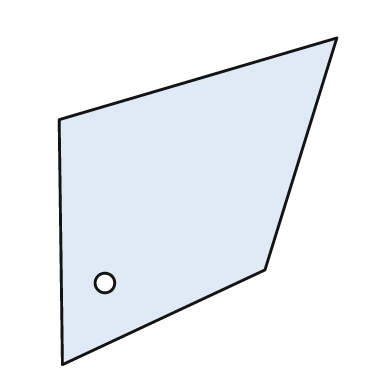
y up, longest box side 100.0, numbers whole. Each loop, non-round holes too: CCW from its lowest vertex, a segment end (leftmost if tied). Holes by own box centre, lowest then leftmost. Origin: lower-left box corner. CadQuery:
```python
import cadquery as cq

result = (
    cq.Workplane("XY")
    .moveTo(1.0, 0.0)
    .lineTo(63.0, 29.0)
    .lineTo(85.0, 100.0)
    .lineTo(0.0, 75.0)
    .close()
    .moveTo(14.0, 25.0)
    .circle(3.0)
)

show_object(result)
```